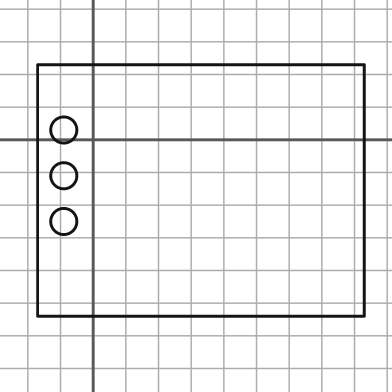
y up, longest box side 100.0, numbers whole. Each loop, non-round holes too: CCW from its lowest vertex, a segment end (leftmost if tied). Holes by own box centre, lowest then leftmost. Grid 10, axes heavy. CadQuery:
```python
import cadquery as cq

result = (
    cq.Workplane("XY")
    .moveTo(-17.0, -54.0)
    .lineTo(83.0, -54.0)
    .lineTo(83.0, 23.0)
    .lineTo(-17.0, 23.0)
    .close()
    .moveTo(-9.0, -25.0)
    .circle(4.0)
    .moveTo(-9.0, -11.0)
    .circle(4.0)
    .moveTo(-9.0, 3.0)
    .circle(4.0)
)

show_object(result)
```